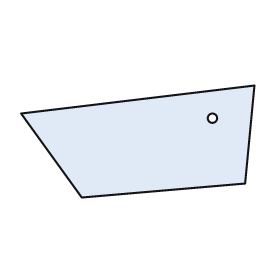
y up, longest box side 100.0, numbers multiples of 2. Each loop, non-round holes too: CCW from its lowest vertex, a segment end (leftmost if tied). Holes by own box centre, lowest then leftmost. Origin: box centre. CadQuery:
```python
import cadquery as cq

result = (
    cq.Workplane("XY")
    .moveTo(-24.0, -24.0)
    .lineTo(46.0, -18.0)
    .lineTo(50.0, 24.0)
    .lineTo(-50.0, 12.0)
    .close()
    .moveTo(32.0, 10.0)
    .circle(2.0)
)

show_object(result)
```